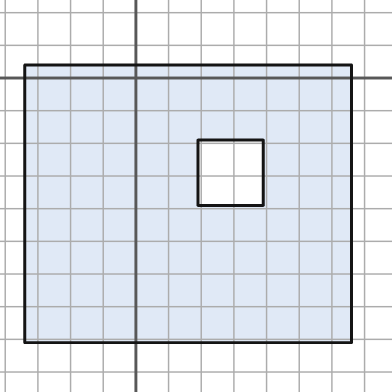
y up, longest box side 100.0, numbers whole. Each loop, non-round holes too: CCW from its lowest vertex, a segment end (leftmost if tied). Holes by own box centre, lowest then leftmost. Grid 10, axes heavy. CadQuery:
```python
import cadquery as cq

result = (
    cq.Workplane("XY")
    .moveTo(-34.0, -81.0)
    .lineTo(66.0, -81.0)
    .lineTo(66.0, 4.0)
    .lineTo(-34.0, 4.0)
    .close()
    .moveTo(19.0, -39.0)
    .lineTo(39.0, -39.0)
    .lineTo(39.0, -19.0)
    .lineTo(19.0, -19.0)
    .close()
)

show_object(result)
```